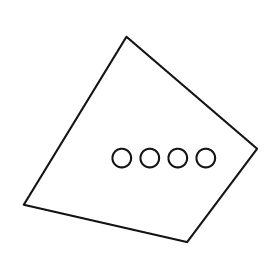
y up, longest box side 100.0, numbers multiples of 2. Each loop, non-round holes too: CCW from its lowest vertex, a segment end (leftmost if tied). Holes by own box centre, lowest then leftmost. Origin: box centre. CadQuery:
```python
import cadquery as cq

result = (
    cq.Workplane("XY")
    .moveTo(20.0, -44.0)
    .lineTo(50.0, -4.0)
    .lineTo(-6.0, 44.0)
    .lineTo(-50.0, -28.0)
    .close()
    .moveTo(-8.0, -8.0)
    .circle(4.0)
    .moveTo(4.0, -8.0)
    .circle(4.0)
    .moveTo(16.0, -8.0)
    .circle(4.0)
    .moveTo(28.0, -8.0)
    .circle(4.0)
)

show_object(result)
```